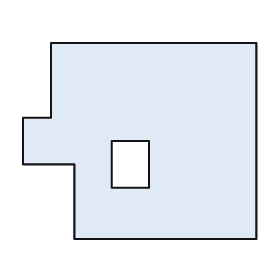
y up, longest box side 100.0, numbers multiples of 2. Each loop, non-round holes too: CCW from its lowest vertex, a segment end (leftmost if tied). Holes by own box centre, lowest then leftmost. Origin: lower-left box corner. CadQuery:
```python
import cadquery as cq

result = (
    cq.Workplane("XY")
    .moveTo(22.0, 0.0)
    .lineTo(100.0, 0.0)
    .lineTo(100.0, 84.0)
    .lineTo(12.0, 84.0)
    .lineTo(12.0, 52.0)
    .lineTo(0.0, 52.0)
    .lineTo(0.0, 32.0)
    .lineTo(22.0, 32.0)
    .close()
    .moveTo(38.0, 22.0)
    .lineTo(54.0, 22.0)
    .lineTo(54.0, 42.0)
    .lineTo(38.0, 42.0)
    .close()
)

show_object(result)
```